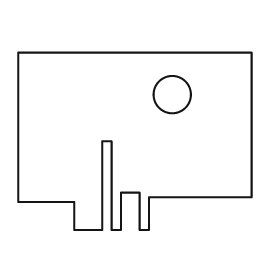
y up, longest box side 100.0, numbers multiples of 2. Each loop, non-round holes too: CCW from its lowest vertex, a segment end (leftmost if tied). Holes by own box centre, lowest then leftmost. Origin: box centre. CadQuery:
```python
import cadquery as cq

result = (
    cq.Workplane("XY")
    .moveTo(-26.0, -38.0)
    .lineTo(-14.0, -38.0)
    .lineTo(-14.0, 0.0)
    .lineTo(-10.0, 0.0)
    .lineTo(-10.0, -38.0)
    .lineTo(-6.0, -38.0)
    .lineTo(-6.0, -22.0)
    .lineTo(2.0, -22.0)
    .lineTo(2.0, -38.0)
    .lineTo(6.0, -38.0)
    .lineTo(6.0, -24.0)
    .lineTo(50.0, -24.0)
    .lineTo(50.0, 38.0)
    .lineTo(-50.0, 38.0)
    .lineTo(-50.0, -26.0)
    .lineTo(-26.0, -26.0)
    .close()
    .moveTo(16.0, 20.0)
    .circle(8.0)
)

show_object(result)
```